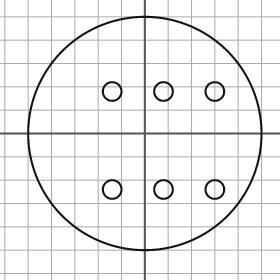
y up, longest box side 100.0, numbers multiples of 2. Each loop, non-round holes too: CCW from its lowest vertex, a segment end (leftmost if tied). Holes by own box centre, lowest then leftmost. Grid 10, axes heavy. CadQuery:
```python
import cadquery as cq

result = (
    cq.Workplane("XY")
    .moveTo(0.0, 0.0)
    .circle(50.0)
    .moveTo(-14.0, -24.0)
    .circle(4.0)
    .moveTo(8.0, -24.0)
    .circle(4.0)
    .moveTo(30.0, -24.0)
    .circle(4.0)
    .moveTo(-14.0, 18.0)
    .circle(4.0)
    .moveTo(8.0, 18.0)
    .circle(4.0)
    .moveTo(30.0, 18.0)
    .circle(4.0)
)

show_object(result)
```